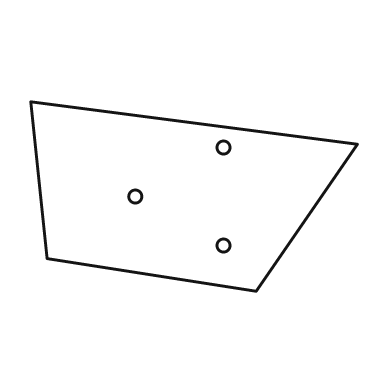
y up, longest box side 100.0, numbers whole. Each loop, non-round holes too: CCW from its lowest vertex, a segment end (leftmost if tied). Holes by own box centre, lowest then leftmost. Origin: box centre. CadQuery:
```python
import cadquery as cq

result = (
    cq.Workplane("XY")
    .moveTo(19.0, -29.0)
    .lineTo(50.0, 16.0)
    .lineTo(-50.0, 29.0)
    .lineTo(-45.0, -19.0)
    .close()
    .moveTo(9.0, -15.0)
    .circle(2.0)
    .moveTo(-18.0, 0.0)
    .circle(2.0)
    .moveTo(9.0, 15.0)
    .circle(2.0)
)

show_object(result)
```